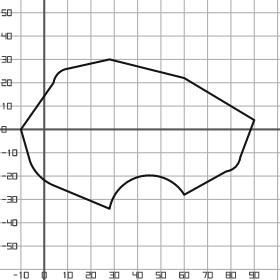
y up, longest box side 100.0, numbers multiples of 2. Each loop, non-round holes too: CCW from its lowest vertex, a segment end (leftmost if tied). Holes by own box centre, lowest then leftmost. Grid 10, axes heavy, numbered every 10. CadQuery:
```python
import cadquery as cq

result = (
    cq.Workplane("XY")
    .moveTo(28.0, -34.0)
    .threePointArc((42.0, -20.0), (60.0, -28.0))
    .lineTo(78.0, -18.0)
    .threePointArc((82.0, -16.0), (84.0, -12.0))
    .lineTo(90.0, 4.0)
    .lineTo(60.0, 22.0)
    .lineTo(28.0, 30.0)
    .lineTo(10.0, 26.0)
    .threePointArc((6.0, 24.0), (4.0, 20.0))
    .lineTo(-10.0, 0.0)
    .lineTo(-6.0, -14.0)
    .threePointArc((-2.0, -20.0), (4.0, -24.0))
    .close()
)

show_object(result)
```